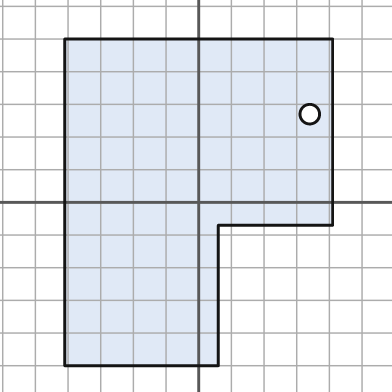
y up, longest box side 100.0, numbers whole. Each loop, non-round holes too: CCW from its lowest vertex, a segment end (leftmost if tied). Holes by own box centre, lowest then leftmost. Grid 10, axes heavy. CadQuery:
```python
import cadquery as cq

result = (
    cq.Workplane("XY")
    .moveTo(-41.0, -50.0)
    .lineTo(6.0, -50.0)
    .lineTo(6.0, -7.0)
    .lineTo(41.0, -7.0)
    .lineTo(41.0, 50.0)
    .lineTo(-41.0, 50.0)
    .close()
    .moveTo(34.0, 27.0)
    .circle(3.0)
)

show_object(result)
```